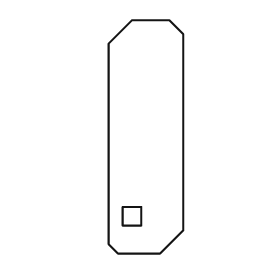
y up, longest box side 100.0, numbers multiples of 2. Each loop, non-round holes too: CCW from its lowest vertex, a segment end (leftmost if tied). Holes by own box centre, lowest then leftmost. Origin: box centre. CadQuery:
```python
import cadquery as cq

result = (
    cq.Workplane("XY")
    .moveTo(-12.0, -50.0)
    .lineTo(6.0, -50.0)
    .lineTo(16.0, -40.0)
    .lineTo(16.0, 44.0)
    .lineTo(10.0, 50.0)
    .lineTo(-6.0, 50.0)
    .lineTo(-16.0, 40.0)
    .lineTo(-16.0, -46.0)
    .close()
    .moveTo(-10.0, -38.0)
    .lineTo(-2.0, -38.0)
    .lineTo(-2.0, -30.0)
    .lineTo(-10.0, -30.0)
    .close()
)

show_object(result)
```